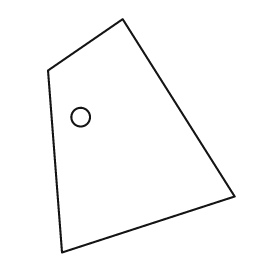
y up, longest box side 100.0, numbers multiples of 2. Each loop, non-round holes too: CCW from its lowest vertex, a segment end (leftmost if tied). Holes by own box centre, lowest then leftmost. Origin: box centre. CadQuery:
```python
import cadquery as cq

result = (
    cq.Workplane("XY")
    .moveTo(-34.0, -50.0)
    .lineTo(40.0, -26.0)
    .lineTo(-8.0, 50.0)
    .lineTo(-40.0, 28.0)
    .close()
    .moveTo(-26.0, 8.0)
    .circle(4.0)
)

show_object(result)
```